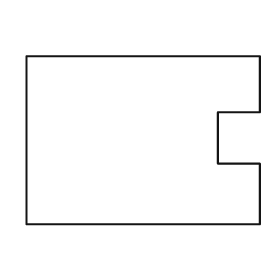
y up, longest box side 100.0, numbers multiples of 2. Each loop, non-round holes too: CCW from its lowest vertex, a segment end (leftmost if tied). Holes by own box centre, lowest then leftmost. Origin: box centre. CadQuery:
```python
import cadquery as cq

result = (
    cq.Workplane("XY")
    .moveTo(-50.0, -36.0)
    .lineTo(50.0, -36.0)
    .lineTo(50.0, -10.0)
    .lineTo(32.0, -10.0)
    .lineTo(32.0, 12.0)
    .lineTo(50.0, 12.0)
    .lineTo(50.0, 36.0)
    .lineTo(-50.0, 36.0)
    .close()
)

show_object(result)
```